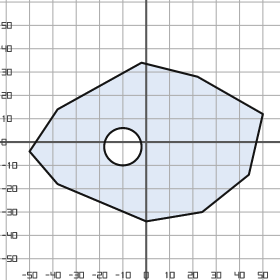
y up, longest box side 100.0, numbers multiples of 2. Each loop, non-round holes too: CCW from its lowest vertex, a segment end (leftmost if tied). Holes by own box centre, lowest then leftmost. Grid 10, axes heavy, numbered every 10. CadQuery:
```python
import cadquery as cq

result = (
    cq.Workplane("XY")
    .moveTo(0.0, -34.0)
    .lineTo(24.0, -30.0)
    .lineTo(44.0, -14.0)
    .lineTo(50.0, 12.0)
    .lineTo(22.0, 28.0)
    .lineTo(-2.0, 34.0)
    .lineTo(-38.0, 14.0)
    .lineTo(-50.0, -4.0)
    .lineTo(-38.0, -18.0)
    .close()
    .moveTo(-10.0, -2.0)
    .circle(8.0)
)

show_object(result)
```